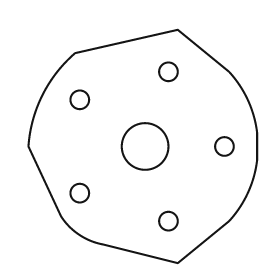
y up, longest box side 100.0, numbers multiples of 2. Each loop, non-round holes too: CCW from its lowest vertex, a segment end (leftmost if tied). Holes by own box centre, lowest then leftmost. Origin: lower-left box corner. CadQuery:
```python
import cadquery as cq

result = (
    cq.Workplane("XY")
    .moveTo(64.0, 0.0)
    .lineTo(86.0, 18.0)
    .threePointArc((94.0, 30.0), (98.0, 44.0))
    .lineTo(98.0, 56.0)
    .threePointArc((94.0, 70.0), (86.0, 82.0))
    .lineTo(64.0, 100.0)
    .lineTo(20.0, 90.0)
    .threePointArc((6.0, 72.0), (0.0, 50.0))
    .lineTo(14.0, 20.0)
    .threePointArc((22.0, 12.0), (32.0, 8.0))
    .close()
    .moveTo(60.0, 18.0)
    .circle(4.0)
    .moveTo(22.0, 30.0)
    .circle(4.0)
    .moveTo(50.0, 50.0)
    .circle(10.0)
    .moveTo(84.0, 50.0)
    .circle(4.0)
    .moveTo(22.0, 70.0)
    .circle(4.0)
    .moveTo(60.0, 82.0)
    .circle(4.0)
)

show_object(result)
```